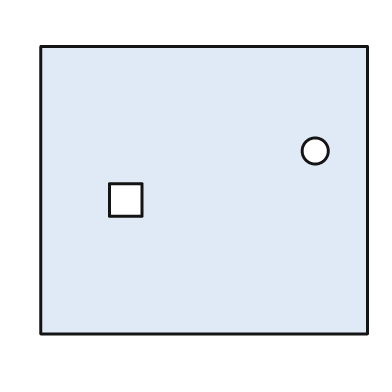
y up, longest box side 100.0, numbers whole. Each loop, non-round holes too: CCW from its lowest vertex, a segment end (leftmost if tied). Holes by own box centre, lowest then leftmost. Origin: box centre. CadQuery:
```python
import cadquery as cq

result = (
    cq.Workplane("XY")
    .moveTo(-50.0, -44.0)
    .lineTo(50.0, -44.0)
    .lineTo(50.0, 44.0)
    .lineTo(-50.0, 44.0)
    .close()
    .moveTo(-29.0, -8.0)
    .lineTo(-19.0, -8.0)
    .lineTo(-19.0, 2.0)
    .lineTo(-29.0, 2.0)
    .close()
    .moveTo(34.0, 12.0)
    .circle(4.0)
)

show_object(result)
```